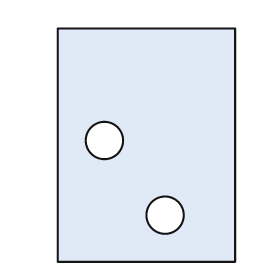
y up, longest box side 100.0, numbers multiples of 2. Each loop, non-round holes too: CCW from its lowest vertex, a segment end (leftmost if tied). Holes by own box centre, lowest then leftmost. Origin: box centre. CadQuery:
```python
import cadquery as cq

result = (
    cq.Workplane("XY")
    .moveTo(-38.0, -50.0)
    .lineTo(38.0, -50.0)
    .lineTo(38.0, 50.0)
    .lineTo(-38.0, 50.0)
    .close()
    .moveTo(8.0, -30.0)
    .circle(8.0)
    .moveTo(-18.0, 2.0)
    .circle(8.0)
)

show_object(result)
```